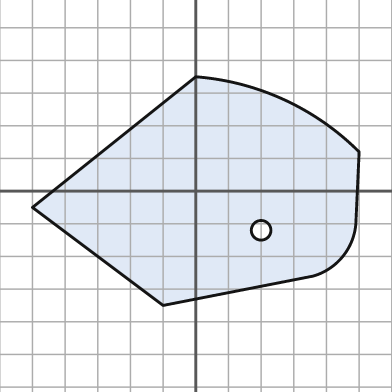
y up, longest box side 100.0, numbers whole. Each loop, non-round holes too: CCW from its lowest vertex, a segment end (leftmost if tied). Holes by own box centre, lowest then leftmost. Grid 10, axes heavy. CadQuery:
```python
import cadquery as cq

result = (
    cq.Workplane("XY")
    .moveTo(-10.0, -35.0)
    .lineTo(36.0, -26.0)
    .threePointArc((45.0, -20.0), (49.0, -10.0))
    .lineTo(50.0, 12.0)
    .threePointArc((27.0, 28.0), (0.0, 35.0))
    .lineTo(-50.0, -5.0)
    .close()
    .moveTo(20.0, -12.0)
    .circle(3.0)
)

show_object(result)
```